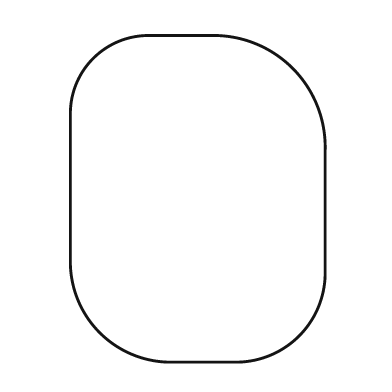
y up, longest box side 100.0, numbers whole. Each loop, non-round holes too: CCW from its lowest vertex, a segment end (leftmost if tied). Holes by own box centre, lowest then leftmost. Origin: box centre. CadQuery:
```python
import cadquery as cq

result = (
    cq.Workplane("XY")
    .moveTo(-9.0, -50.0)
    .lineTo(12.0, -50.0)
    .threePointArc((31.0, -42.0), (39.0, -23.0))
    .lineTo(39.0, 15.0)
    .threePointArc((29.0, 40.0), (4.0, 50.0))
    .lineTo(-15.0, 50.0)
    .threePointArc((-32.0, 43.0), (-39.0, 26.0))
    .lineTo(-39.0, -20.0)
    .threePointArc((-30.0, -41.0), (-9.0, -50.0))
    .close()
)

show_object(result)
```